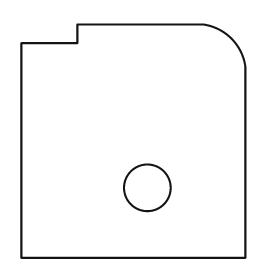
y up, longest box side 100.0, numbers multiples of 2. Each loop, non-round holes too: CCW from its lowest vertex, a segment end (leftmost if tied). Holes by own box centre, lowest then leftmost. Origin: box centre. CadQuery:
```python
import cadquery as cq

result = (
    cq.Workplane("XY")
    .moveTo(-48.0, -50.0)
    .lineTo(48.0, -50.0)
    .lineTo(48.0, 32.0)
    .threePointArc((42.0, 44.0), (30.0, 50.0))
    .lineTo(-24.0, 50.0)
    .lineTo(-24.0, 42.0)
    .lineTo(-48.0, 42.0)
    .close()
    .moveTo(6.0, -20.0)
    .circle(10.0)
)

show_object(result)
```